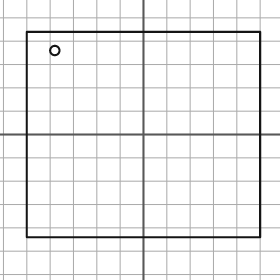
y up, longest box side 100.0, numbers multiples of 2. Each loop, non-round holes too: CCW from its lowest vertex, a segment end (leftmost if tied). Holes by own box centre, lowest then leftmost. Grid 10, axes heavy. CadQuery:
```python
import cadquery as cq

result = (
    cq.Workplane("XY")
    .moveTo(-50.0, -44.0)
    .lineTo(50.0, -44.0)
    .lineTo(50.0, 44.0)
    .lineTo(-50.0, 44.0)
    .close()
    .moveTo(-38.0, 36.0)
    .circle(2.0)
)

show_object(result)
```